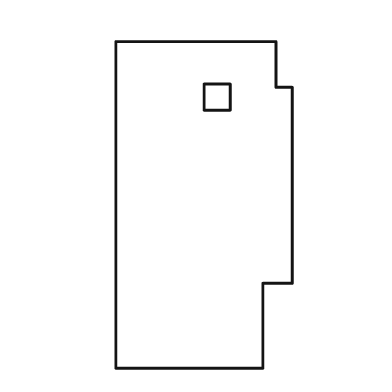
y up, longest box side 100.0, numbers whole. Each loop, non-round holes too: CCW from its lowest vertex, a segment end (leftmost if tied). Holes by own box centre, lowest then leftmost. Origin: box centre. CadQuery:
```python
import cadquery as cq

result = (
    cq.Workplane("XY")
    .moveTo(-27.0, -50.0)
    .lineTo(18.0, -50.0)
    .lineTo(18.0, -24.0)
    .lineTo(27.0, -24.0)
    .lineTo(27.0, 36.0)
    .lineTo(22.0, 36.0)
    .lineTo(22.0, 50.0)
    .lineTo(-27.0, 50.0)
    .close()
    .moveTo(0.0, 29.0)
    .lineTo(8.0, 29.0)
    .lineTo(8.0, 37.0)
    .lineTo(0.0, 37.0)
    .close()
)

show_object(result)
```